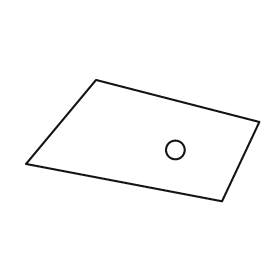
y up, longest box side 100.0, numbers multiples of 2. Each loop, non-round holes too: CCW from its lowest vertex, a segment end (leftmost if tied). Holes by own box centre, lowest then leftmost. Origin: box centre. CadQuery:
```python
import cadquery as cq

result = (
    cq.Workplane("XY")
    .moveTo(34.0, -26.0)
    .lineTo(50.0, 8.0)
    .lineTo(-20.0, 26.0)
    .lineTo(-50.0, -10.0)
    .close()
    .moveTo(14.0, -4.0)
    .circle(4.0)
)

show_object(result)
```